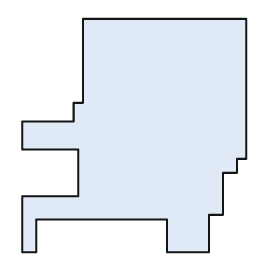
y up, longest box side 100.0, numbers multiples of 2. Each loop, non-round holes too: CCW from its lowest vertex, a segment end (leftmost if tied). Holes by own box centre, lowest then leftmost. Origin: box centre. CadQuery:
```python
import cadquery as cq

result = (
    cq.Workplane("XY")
    .moveTo(-48.0, -50.0)
    .lineTo(-42.0, -50.0)
    .lineTo(-42.0, -36.0)
    .lineTo(14.0, -36.0)
    .lineTo(14.0, -50.0)
    .lineTo(32.0, -50.0)
    .lineTo(32.0, -34.0)
    .lineTo(38.0, -34.0)
    .lineTo(38.0, -16.0)
    .lineTo(44.0, -16.0)
    .lineTo(44.0, -10.0)
    .lineTo(48.0, -10.0)
    .lineTo(48.0, 50.0)
    .lineTo(-22.0, 50.0)
    .lineTo(-22.0, 14.0)
    .lineTo(-26.0, 14.0)
    .lineTo(-26.0, 6.0)
    .lineTo(-48.0, 6.0)
    .lineTo(-48.0, -6.0)
    .lineTo(-24.0, -6.0)
    .lineTo(-24.0, -26.0)
    .lineTo(-48.0, -26.0)
    .close()
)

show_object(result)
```